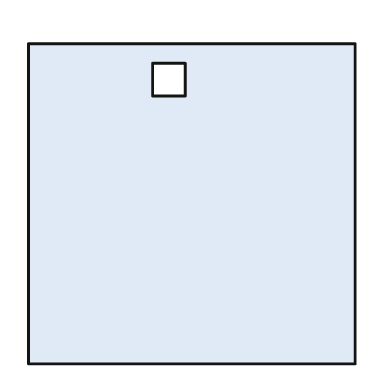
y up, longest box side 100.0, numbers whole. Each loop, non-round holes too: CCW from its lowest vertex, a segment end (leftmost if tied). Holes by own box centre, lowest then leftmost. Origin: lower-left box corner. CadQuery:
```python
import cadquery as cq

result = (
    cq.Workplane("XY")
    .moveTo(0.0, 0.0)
    .lineTo(100.0, 0.0)
    .lineTo(100.0, 98.0)
    .lineTo(0.0, 98.0)
    .close()
    .moveTo(38.0, 82.0)
    .lineTo(48.0, 82.0)
    .lineTo(48.0, 92.0)
    .lineTo(38.0, 92.0)
    .close()
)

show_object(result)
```